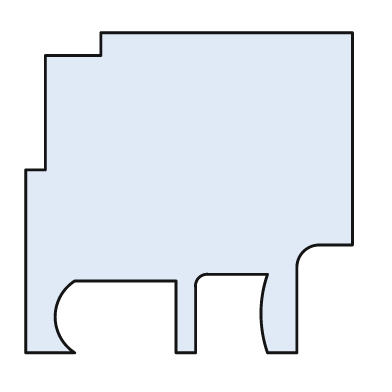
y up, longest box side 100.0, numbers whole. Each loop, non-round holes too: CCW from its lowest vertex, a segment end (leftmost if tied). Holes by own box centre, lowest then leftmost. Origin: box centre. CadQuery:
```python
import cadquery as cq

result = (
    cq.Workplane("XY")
    .moveTo(-50.0, -49.0)
    .lineTo(-35.0, -49.0)
    .threePointArc((-41.0, -38.0), (-35.0, -27.0))
    .lineTo(-4.0, -27.0)
    .lineTo(-4.0, -49.0)
    .lineTo(2.0, -49.0)
    .lineTo(2.0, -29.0)
    .threePointArc((3.0, -26.0), (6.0, -25.0))
    .lineTo(24.0, -25.0)
    .threePointArc((22.0, -37.0), (24.0, -49.0))
    .lineTo(33.0, -49.0)
    .lineTo(33.0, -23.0)
    .threePointArc((35.0, -18.0), (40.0, -16.0))
    .lineTo(50.0, -16.0)
    .lineTo(50.0, 49.0)
    .lineTo(-27.0, 49.0)
    .lineTo(-27.0, 42.0)
    .lineTo(-44.0, 42.0)
    .lineTo(-44.0, 7.0)
    .lineTo(-50.0, 7.0)
    .close()
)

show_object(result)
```